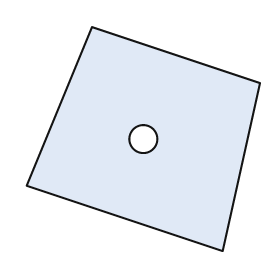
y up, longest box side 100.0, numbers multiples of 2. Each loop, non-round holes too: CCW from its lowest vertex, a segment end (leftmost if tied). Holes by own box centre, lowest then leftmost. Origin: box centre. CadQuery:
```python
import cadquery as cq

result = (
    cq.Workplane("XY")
    .moveTo(34.0, -48.0)
    .lineTo(50.0, 24.0)
    .lineTo(-22.0, 48.0)
    .lineTo(-50.0, -20.0)
    .close()
    .moveTo(0.0, 0.0)
    .circle(6.0)
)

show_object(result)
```